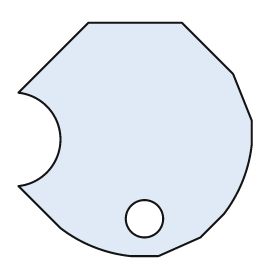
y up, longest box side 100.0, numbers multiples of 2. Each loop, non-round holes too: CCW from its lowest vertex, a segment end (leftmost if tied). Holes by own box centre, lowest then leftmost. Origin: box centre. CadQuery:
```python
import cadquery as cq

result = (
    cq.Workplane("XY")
    .moveTo(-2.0, -50.0)
    .lineTo(10.0, -50.0)
    .lineTo(28.0, -42.0)
    .lineTo(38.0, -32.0)
    .threePointArc((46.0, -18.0), (50.0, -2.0))
    .lineTo(50.0, 8.0)
    .lineTo(42.0, 28.0)
    .lineTo(20.0, 50.0)
    .lineTo(-20.0, 50.0)
    .lineTo(-50.0, 20.0)
    .threePointArc((-32.0, 0.0), (-50.0, -20.0))
    .lineTo(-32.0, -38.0)
    .threePointArc((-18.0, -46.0), (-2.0, -50.0))
    .close()
    .moveTo(4.0, -34.0)
    .circle(8.0)
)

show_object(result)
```